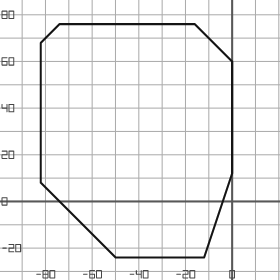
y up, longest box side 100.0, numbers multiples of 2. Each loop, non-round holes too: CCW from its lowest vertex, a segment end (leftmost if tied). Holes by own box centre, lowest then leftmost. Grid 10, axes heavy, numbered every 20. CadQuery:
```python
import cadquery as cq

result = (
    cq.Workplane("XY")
    .moveTo(-50.0, -24.0)
    .lineTo(-12.0, -24.0)
    .lineTo(0.0, 12.0)
    .lineTo(0.0, 60.0)
    .lineTo(-16.0, 76.0)
    .lineTo(-74.0, 76.0)
    .lineTo(-82.0, 68.0)
    .lineTo(-82.0, 8.0)
    .close()
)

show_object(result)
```